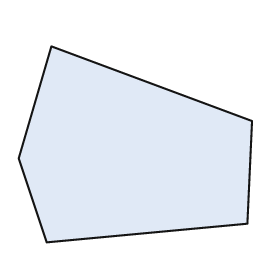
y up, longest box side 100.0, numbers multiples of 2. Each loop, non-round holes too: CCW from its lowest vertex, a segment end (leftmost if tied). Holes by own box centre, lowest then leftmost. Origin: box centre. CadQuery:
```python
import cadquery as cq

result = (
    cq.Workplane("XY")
    .moveTo(-38.0, -42.0)
    .lineTo(48.0, -34.0)
    .lineTo(50.0, 10.0)
    .lineTo(-36.0, 42.0)
    .lineTo(-50.0, -6.0)
    .close()
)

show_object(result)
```